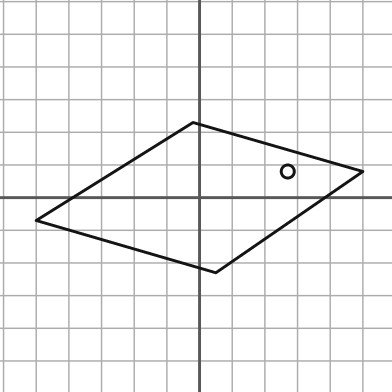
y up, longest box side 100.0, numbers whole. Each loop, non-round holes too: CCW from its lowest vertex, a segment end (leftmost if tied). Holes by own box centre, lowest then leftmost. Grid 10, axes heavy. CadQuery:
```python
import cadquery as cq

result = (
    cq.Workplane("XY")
    .moveTo(5.0, -23.0)
    .lineTo(50.0, 8.0)
    .lineTo(-2.0, 23.0)
    .lineTo(-50.0, -7.0)
    .close()
    .moveTo(27.0, 8.0)
    .circle(2.0)
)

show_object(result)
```